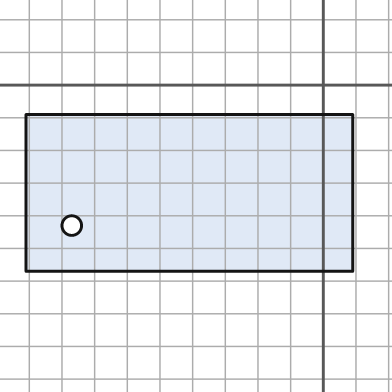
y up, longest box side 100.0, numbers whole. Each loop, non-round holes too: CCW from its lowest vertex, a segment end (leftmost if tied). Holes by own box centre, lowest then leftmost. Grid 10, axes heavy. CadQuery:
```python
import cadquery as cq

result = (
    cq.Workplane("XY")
    .moveTo(-91.0, -57.0)
    .lineTo(9.0, -57.0)
    .lineTo(9.0, -9.0)
    .lineTo(-91.0, -9.0)
    .close()
    .moveTo(-77.0, -43.0)
    .circle(3.0)
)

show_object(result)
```